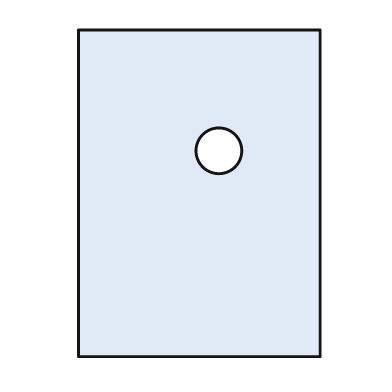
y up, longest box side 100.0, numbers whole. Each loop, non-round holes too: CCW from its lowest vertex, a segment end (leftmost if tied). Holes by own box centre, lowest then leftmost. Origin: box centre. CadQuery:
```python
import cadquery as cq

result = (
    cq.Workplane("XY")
    .moveTo(-37.0, -50.0)
    .lineTo(37.0, -50.0)
    .lineTo(37.0, 50.0)
    .lineTo(-37.0, 50.0)
    .close()
    .moveTo(6.0, 13.0)
    .circle(7.0)
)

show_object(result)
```